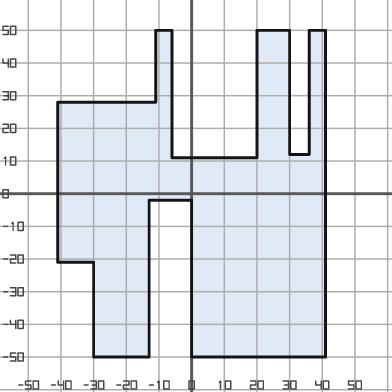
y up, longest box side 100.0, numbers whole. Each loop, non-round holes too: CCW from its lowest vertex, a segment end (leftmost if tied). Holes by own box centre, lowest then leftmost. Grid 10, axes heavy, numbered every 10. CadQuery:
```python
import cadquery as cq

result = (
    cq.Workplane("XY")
    .moveTo(-30.0, -50.0)
    .lineTo(-13.0, -50.0)
    .lineTo(-13.0, -2.0)
    .lineTo(0.0, -2.0)
    .lineTo(0.0, -50.0)
    .lineTo(41.0, -50.0)
    .lineTo(41.0, 50.0)
    .lineTo(36.0, 50.0)
    .lineTo(36.0, 12.0)
    .lineTo(30.0, 12.0)
    .lineTo(30.0, 50.0)
    .lineTo(20.0, 50.0)
    .lineTo(20.0, 11.0)
    .lineTo(-6.0, 11.0)
    .lineTo(-6.0, 50.0)
    .lineTo(-11.0, 50.0)
    .lineTo(-11.0, 28.0)
    .lineTo(-41.0, 28.0)
    .lineTo(-41.0, -21.0)
    .lineTo(-30.0, -21.0)
    .close()
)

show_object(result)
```